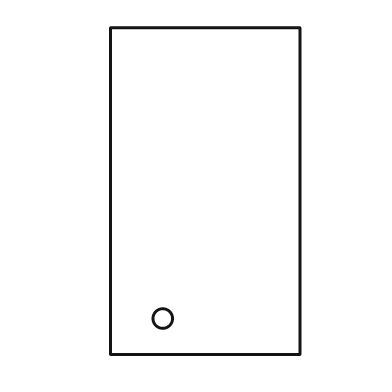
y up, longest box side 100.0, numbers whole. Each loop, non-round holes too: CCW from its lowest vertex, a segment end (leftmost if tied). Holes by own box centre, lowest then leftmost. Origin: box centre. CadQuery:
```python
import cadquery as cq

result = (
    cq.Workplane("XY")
    .moveTo(-29.0, -50.0)
    .lineTo(29.0, -50.0)
    .lineTo(29.0, 50.0)
    .lineTo(-29.0, 50.0)
    .close()
    .moveTo(-13.0, -39.0)
    .circle(3.0)
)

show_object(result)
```